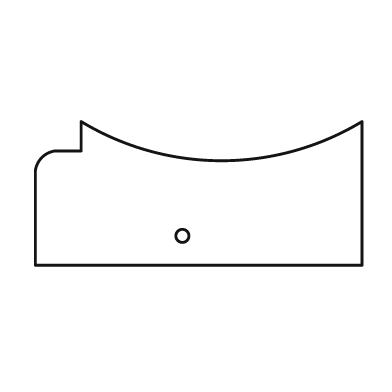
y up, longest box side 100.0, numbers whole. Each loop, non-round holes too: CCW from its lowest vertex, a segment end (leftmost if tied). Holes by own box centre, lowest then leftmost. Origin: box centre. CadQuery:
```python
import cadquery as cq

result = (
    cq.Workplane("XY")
    .moveTo(-50.0, -22.0)
    .lineTo(50.0, -22.0)
    .lineTo(50.0, 22.0)
    .threePointArc((7.0, 10.0), (-36.0, 22.0))
    .lineTo(-36.0, 13.0)
    .lineTo(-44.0, 13.0)
    .threePointArc((-48.0, 11.0), (-50.0, 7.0))
    .close()
    .moveTo(-5.0, -13.0)
    .circle(2.0)
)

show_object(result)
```